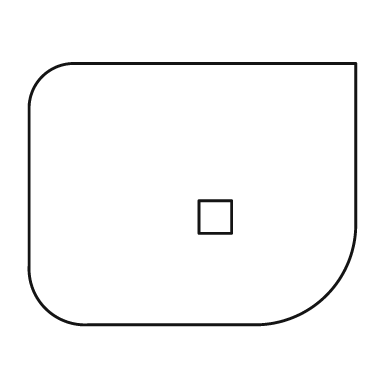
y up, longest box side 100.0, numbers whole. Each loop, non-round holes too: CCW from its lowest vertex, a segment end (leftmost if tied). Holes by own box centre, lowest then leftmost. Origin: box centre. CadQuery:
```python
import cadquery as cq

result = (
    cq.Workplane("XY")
    .moveTo(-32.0, -40.0)
    .lineTo(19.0, -40.0)
    .threePointArc((41.0, -31.0), (50.0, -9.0))
    .lineTo(50.0, 40.0)
    .lineTo(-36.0, 40.0)
    .threePointArc((-46.0, 36.0), (-50.0, 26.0))
    .lineTo(-50.0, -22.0)
    .threePointArc((-45.0, -35.0), (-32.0, -40.0))
    .close()
    .moveTo(2.0, -12.0)
    .lineTo(12.0, -12.0)
    .lineTo(12.0, -2.0)
    .lineTo(2.0, -2.0)
    .close()
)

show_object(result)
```